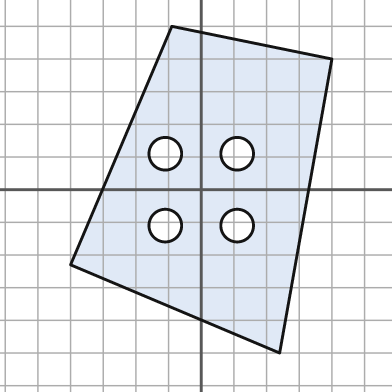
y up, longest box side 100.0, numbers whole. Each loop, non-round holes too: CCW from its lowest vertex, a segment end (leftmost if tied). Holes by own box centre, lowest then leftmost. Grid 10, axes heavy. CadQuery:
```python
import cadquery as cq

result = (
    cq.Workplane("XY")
    .moveTo(24.0, -50.0)
    .lineTo(40.0, 40.0)
    .lineTo(-9.0, 50.0)
    .lineTo(-40.0, -23.0)
    .close()
    .moveTo(-11.0, -11.0)
    .circle(5.0)
    .moveTo(11.0, -11.0)
    .circle(5.0)
    .moveTo(-11.0, 11.0)
    .circle(5.0)
    .moveTo(11.0, 11.0)
    .circle(5.0)
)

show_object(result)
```